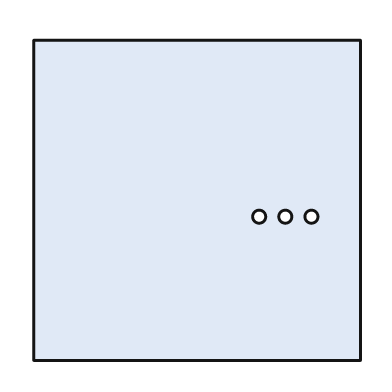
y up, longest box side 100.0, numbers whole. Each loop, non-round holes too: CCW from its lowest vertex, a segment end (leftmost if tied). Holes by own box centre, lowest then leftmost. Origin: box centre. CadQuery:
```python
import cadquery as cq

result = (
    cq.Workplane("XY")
    .moveTo(-50.0, -49.0)
    .lineTo(50.0, -49.0)
    .lineTo(50.0, 49.0)
    .lineTo(-50.0, 49.0)
    .close()
    .moveTo(19.0, -5.0)
    .circle(2.0)
    .moveTo(27.0, -5.0)
    .circle(2.0)
    .moveTo(35.0, -5.0)
    .circle(2.0)
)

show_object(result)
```